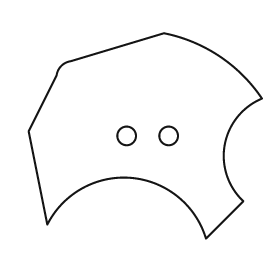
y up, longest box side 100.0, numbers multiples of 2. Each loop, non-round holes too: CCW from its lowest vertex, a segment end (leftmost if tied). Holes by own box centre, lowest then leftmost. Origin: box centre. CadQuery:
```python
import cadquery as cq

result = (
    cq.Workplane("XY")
    .moveTo(26.0, -44.0)
    .lineTo(42.0, -28.0)
    .threePointArc((34.0, -4.0), (50.0, 16.0))
    .threePointArc((32.0, 34.0), (8.0, 44.0))
    .lineTo(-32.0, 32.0)
    .threePointArc((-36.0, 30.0), (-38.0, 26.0))
    .lineTo(-50.0, 2.0)
    .lineTo(-42.0, -38.0)
    .threePointArc((-6.0, -18.0), (26.0, -44.0))
    .close()
    .moveTo(-8.0, 0.0)
    .circle(4.0)
    .moveTo(10.0, 0.0)
    .circle(4.0)
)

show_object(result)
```